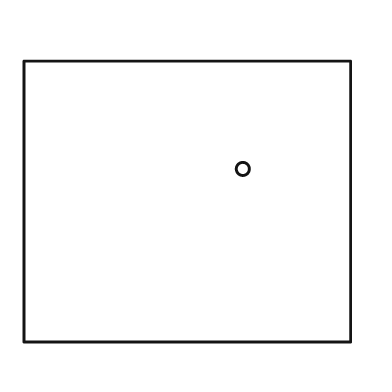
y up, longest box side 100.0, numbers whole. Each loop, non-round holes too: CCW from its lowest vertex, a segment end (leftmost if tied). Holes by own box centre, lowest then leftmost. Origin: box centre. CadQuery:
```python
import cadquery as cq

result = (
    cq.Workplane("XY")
    .moveTo(-50.0, -43.0)
    .lineTo(50.0, -43.0)
    .lineTo(50.0, 43.0)
    .lineTo(-50.0, 43.0)
    .close()
    .moveTo(17.0, 10.0)
    .circle(2.0)
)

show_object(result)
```